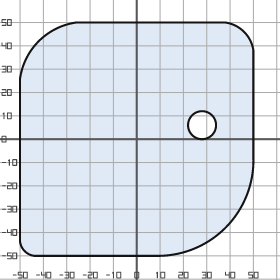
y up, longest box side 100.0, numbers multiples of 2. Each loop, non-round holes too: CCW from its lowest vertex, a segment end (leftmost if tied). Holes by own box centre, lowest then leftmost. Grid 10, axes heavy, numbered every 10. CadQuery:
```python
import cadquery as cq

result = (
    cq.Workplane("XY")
    .moveTo(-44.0, -50.0)
    .lineTo(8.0, -50.0)
    .threePointArc((38.0, -38.0), (50.0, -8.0))
    .lineTo(50.0, 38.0)
    .threePointArc((46.0, 46.0), (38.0, 50.0))
    .lineTo(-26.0, 50.0)
    .threePointArc((-42.0, 42.0), (-50.0, 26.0))
    .lineTo(-50.0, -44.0)
    .threePointArc((-48.0, -48.0), (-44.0, -50.0))
    .close()
    .moveTo(28.0, 6.0)
    .circle(6.0)
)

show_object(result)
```